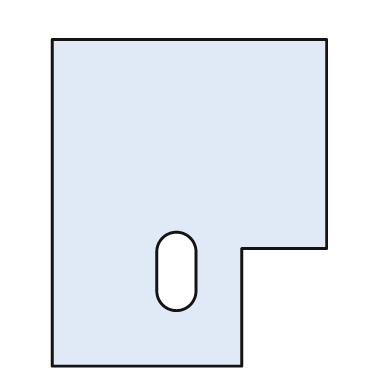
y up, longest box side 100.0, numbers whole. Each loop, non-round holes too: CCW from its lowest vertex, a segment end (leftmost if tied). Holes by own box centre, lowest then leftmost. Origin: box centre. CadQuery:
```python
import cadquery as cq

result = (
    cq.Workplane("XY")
    .moveTo(-42.0, -50.0)
    .lineTo(16.0, -50.0)
    .lineTo(16.0, -14.0)
    .lineTo(42.0, -14.0)
    .lineTo(42.0, 50.0)
    .lineTo(-42.0, 50.0)
    .close()
    .moveTo(-10.0, -27.0)
    .threePointArc((-4.0, -33.0), (2.0, -27.0))
    .lineTo(2.0, -15.0)
    .threePointArc((-4.0, -9.0), (-10.0, -15.0))
    .close()
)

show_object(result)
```